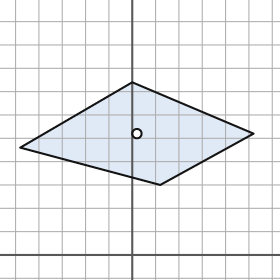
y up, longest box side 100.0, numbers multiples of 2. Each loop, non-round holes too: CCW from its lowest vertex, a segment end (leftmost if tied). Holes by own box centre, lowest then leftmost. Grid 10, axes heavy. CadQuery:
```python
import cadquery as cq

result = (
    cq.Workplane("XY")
    .moveTo(12.0, 30.0)
    .lineTo(52.0, 52.0)
    .lineTo(0.0, 74.0)
    .lineTo(-48.0, 46.0)
    .close()
    .moveTo(2.0, 52.0)
    .circle(2.0)
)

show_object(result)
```